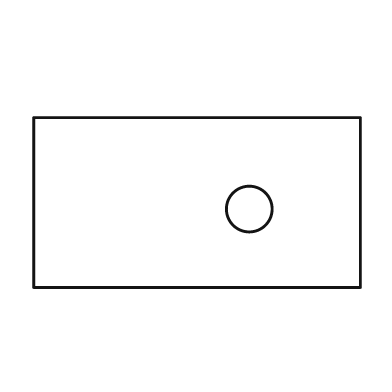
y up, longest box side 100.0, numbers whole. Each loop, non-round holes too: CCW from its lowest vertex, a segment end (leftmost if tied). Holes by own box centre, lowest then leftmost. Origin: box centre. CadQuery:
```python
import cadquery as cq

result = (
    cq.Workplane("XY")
    .moveTo(-50.0, -26.0)
    .lineTo(50.0, -26.0)
    .lineTo(50.0, 26.0)
    .lineTo(-50.0, 26.0)
    .close()
    .moveTo(16.0, -2.0)
    .circle(7.0)
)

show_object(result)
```